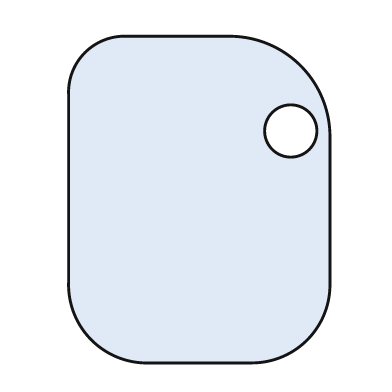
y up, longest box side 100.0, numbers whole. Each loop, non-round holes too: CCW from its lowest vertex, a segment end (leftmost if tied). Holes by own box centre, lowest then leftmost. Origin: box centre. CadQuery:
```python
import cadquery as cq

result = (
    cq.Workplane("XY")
    .moveTo(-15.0, -50.0)
    .lineTo(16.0, -50.0)
    .threePointArc((33.0, -43.0), (40.0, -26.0))
    .lineTo(40.0, 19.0)
    .threePointArc((31.0, 41.0), (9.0, 50.0))
    .lineTo(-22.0, 50.0)
    .threePointArc((-35.0, 45.0), (-40.0, 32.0))
    .lineTo(-40.0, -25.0)
    .threePointArc((-33.0, -43.0), (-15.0, -50.0))
    .close()
    .moveTo(28.0, 21.0)
    .circle(8.0)
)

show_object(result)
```